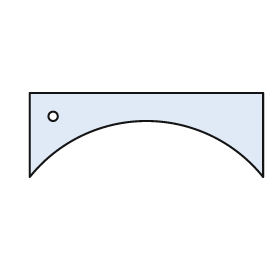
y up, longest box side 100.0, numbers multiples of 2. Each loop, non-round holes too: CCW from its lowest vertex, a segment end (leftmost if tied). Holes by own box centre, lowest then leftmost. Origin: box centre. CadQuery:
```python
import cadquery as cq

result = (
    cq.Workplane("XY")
    .moveTo(-50.0, -18.0)
    .threePointArc((0.0, 6.0), (50.0, -18.0))
    .lineTo(50.0, 18.0)
    .lineTo(-50.0, 18.0)
    .close()
    .moveTo(-40.0, 8.0)
    .circle(2.0)
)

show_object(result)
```